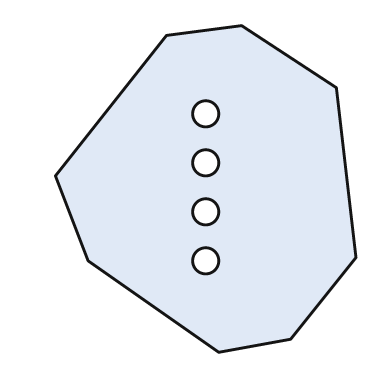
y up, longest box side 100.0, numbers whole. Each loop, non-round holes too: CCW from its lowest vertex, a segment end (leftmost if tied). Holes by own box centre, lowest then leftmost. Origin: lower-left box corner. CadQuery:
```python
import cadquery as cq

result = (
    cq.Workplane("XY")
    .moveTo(50.0, 0.0)
    .lineTo(72.0, 4.0)
    .lineTo(92.0, 29.0)
    .lineTo(86.0, 81.0)
    .lineTo(57.0, 100.0)
    .lineTo(34.0, 97.0)
    .lineTo(0.0, 54.0)
    .lineTo(10.0, 28.0)
    .close()
    .moveTo(46.0, 28.0)
    .circle(4.0)
    .moveTo(46.0, 43.0)
    .circle(4.0)
    .moveTo(46.0, 58.0)
    .circle(4.0)
    .moveTo(46.0, 73.0)
    .circle(4.0)
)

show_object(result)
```